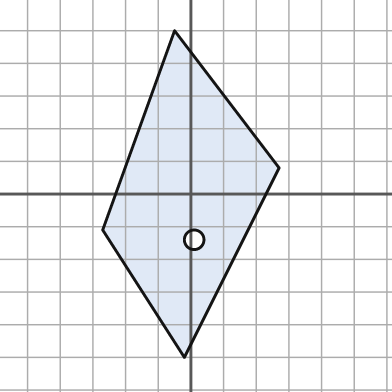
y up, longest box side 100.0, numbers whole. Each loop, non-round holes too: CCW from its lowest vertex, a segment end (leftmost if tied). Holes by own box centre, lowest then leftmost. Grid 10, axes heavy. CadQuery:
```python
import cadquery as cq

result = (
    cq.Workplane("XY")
    .moveTo(-2.0, -50.0)
    .lineTo(27.0, 8.0)
    .lineTo(-5.0, 50.0)
    .lineTo(-27.0, -11.0)
    .close()
    .moveTo(1.0, -14.0)
    .circle(3.0)
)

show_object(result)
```